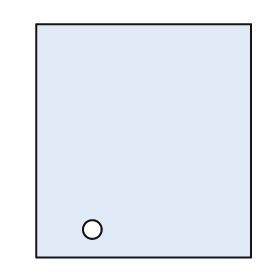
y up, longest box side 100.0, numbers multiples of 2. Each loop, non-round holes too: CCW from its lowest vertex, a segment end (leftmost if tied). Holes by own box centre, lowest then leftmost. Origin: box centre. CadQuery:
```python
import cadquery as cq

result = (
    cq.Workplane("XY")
    .moveTo(-46.0, -50.0)
    .lineTo(46.0, -50.0)
    .lineTo(46.0, 50.0)
    .lineTo(-46.0, 50.0)
    .close()
    .moveTo(-22.0, -38.0)
    .circle(4.0)
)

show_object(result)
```